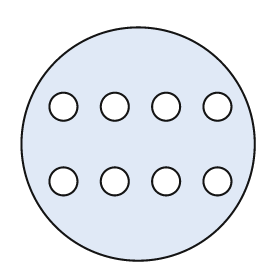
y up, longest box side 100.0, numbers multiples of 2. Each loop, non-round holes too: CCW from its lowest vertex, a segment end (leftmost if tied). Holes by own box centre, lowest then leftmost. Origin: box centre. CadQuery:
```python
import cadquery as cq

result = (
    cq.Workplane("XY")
    .moveTo(0.0, 0.0)
    .circle(50.0)
    .moveTo(-32.0, -16.0)
    .circle(6.0)
    .moveTo(-10.0, -16.0)
    .circle(6.0)
    .moveTo(12.0, -16.0)
    .circle(6.0)
    .moveTo(34.0, -16.0)
    .circle(6.0)
    .moveTo(-32.0, 16.0)
    .circle(6.0)
    .moveTo(-10.0, 16.0)
    .circle(6.0)
    .moveTo(12.0, 16.0)
    .circle(6.0)
    .moveTo(34.0, 16.0)
    .circle(6.0)
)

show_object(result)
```